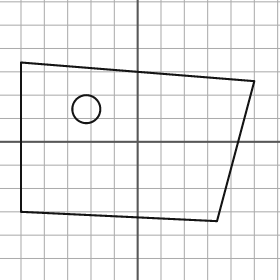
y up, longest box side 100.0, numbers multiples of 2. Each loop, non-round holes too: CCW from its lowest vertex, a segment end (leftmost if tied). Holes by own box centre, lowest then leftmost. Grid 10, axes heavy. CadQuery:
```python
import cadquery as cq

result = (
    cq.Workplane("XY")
    .moveTo(34.0, -34.0)
    .lineTo(50.0, 26.0)
    .lineTo(-50.0, 34.0)
    .lineTo(-50.0, -30.0)
    .close()
    .moveTo(-22.0, 14.0)
    .circle(6.0)
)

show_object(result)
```